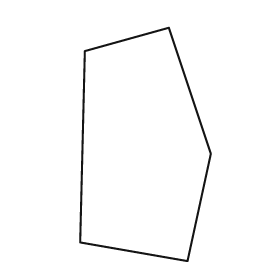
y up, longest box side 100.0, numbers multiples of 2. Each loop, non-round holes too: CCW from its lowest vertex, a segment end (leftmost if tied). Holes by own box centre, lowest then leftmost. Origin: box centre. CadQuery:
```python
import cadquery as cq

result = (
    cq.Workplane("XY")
    .moveTo(18.0, -50.0)
    .lineTo(28.0, -4.0)
    .lineTo(10.0, 50.0)
    .lineTo(-26.0, 40.0)
    .lineTo(-28.0, -42.0)
    .close()
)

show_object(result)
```